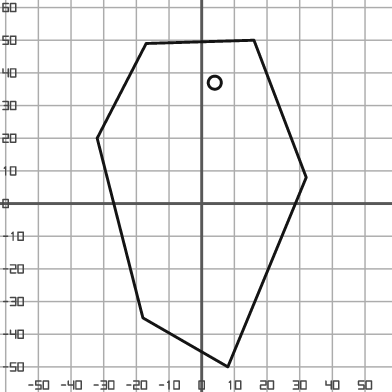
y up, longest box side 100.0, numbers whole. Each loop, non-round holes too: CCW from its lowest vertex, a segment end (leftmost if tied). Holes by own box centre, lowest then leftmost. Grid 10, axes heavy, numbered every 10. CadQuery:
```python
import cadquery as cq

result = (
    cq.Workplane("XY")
    .moveTo(8.0, -50.0)
    .lineTo(32.0, 8.0)
    .lineTo(16.0, 50.0)
    .lineTo(-17.0, 49.0)
    .lineTo(-32.0, 20.0)
    .lineTo(-18.0, -35.0)
    .close()
    .moveTo(4.0, 37.0)
    .circle(2.0)
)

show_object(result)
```